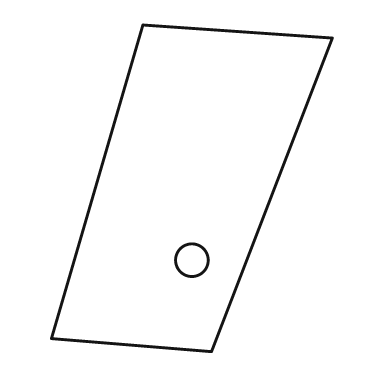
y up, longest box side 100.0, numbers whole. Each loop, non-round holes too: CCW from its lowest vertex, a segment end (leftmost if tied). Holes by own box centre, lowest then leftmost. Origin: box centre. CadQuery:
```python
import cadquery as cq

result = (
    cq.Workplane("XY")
    .moveTo(6.0, -50.0)
    .lineTo(43.0, 46.0)
    .lineTo(-15.0, 50.0)
    .lineTo(-43.0, -46.0)
    .close()
    .moveTo(0.0, -22.0)
    .circle(5.0)
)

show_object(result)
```